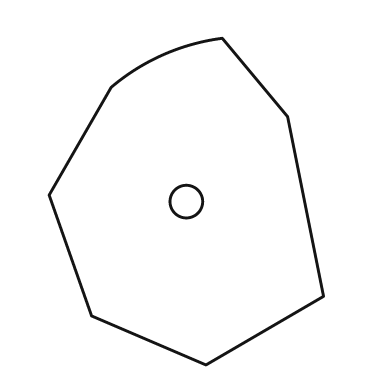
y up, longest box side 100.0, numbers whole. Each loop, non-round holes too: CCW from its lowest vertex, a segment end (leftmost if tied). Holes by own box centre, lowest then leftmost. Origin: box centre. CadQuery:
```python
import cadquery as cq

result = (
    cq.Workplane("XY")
    .moveTo(6.0, -50.0)
    .lineTo(42.0, -29.0)
    .lineTo(31.0, 26.0)
    .lineTo(11.0, 50.0)
    .threePointArc((-7.0, 45.0), (-23.0, 35.0))
    .lineTo(-42.0, 2.0)
    .lineTo(-29.0, -35.0)
    .close()
    .moveTo(0.0, 0.0)
    .circle(5.0)
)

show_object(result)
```